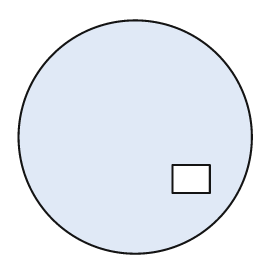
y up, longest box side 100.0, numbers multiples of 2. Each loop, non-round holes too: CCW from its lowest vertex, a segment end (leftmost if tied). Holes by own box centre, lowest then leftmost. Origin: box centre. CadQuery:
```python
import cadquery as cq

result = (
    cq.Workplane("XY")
    .moveTo(0.0, 0.0)
    .circle(50.0)
    .moveTo(16.0, -24.0)
    .lineTo(32.0, -24.0)
    .lineTo(32.0, -12.0)
    .lineTo(16.0, -12.0)
    .close()
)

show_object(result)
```